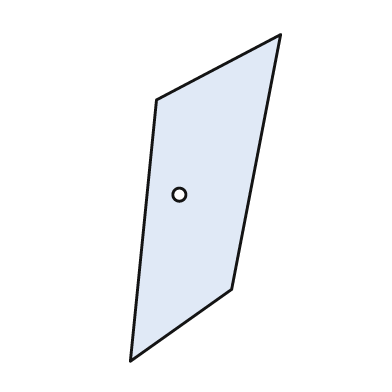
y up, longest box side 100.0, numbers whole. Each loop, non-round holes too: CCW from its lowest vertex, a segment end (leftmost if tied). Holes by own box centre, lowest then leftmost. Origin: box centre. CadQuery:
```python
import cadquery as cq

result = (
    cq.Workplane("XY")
    .moveTo(-23.0, -50.0)
    .lineTo(8.0, -28.0)
    .lineTo(23.0, 50.0)
    .lineTo(-15.0, 30.0)
    .close()
    .moveTo(-8.0, 1.0)
    .circle(2.0)
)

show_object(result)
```